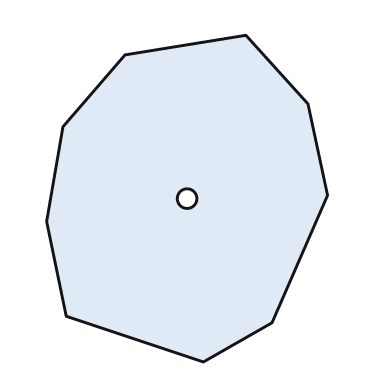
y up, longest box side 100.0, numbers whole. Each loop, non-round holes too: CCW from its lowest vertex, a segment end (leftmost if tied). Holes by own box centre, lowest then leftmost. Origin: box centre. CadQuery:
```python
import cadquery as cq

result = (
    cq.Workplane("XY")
    .moveTo(5.0, -50.0)
    .lineTo(26.0, -38.0)
    .lineTo(43.0, 1.0)
    .lineTo(37.0, 29.0)
    .lineTo(18.0, 50.0)
    .lineTo(-19.0, 44.0)
    .lineTo(-38.0, 22.0)
    .lineTo(-43.0, -7.0)
    .lineTo(-37.0, -36.0)
    .close()
    .moveTo(0.0, 0.0)
    .circle(3.0)
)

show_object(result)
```